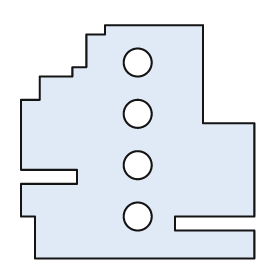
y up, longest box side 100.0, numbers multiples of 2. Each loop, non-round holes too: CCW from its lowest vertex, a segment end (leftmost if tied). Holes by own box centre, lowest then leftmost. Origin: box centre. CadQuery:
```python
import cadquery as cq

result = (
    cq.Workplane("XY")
    .moveTo(-44.0, -50.0)
    .lineTo(50.0, -50.0)
    .lineTo(50.0, -38.0)
    .lineTo(16.0, -38.0)
    .lineTo(16.0, -32.0)
    .lineTo(50.0, -32.0)
    .lineTo(50.0, 8.0)
    .lineTo(28.0, 8.0)
    .lineTo(28.0, 50.0)
    .lineTo(-14.0, 50.0)
    .lineTo(-14.0, 46.0)
    .lineTo(-22.0, 46.0)
    .lineTo(-22.0, 32.0)
    .lineTo(-28.0, 32.0)
    .lineTo(-28.0, 28.0)
    .lineTo(-42.0, 28.0)
    .lineTo(-42.0, 18.0)
    .lineTo(-50.0, 18.0)
    .lineTo(-50.0, -12.0)
    .lineTo(-26.0, -12.0)
    .lineTo(-26.0, -18.0)
    .lineTo(-50.0, -18.0)
    .lineTo(-50.0, -32.0)
    .lineTo(-44.0, -32.0)
    .close()
    .moveTo(0.0, -32.0)
    .circle(6.0)
    .moveTo(0.0, -10.0)
    .circle(6.0)
    .moveTo(0.0, 12.0)
    .circle(6.0)
    .moveTo(0.0, 34.0)
    .circle(6.0)
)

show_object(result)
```